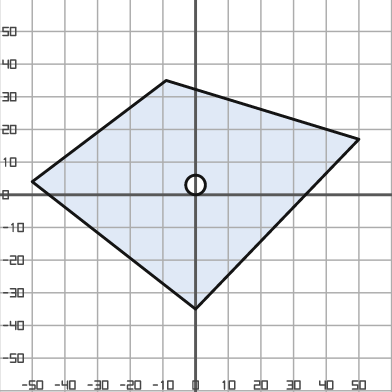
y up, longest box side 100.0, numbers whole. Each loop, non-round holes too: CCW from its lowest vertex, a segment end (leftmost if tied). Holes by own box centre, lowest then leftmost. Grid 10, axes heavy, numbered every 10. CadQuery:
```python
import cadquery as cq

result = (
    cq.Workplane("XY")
    .moveTo(0.0, -35.0)
    .lineTo(50.0, 17.0)
    .lineTo(-9.0, 35.0)
    .lineTo(-50.0, 4.0)
    .close()
    .moveTo(0.0, 3.0)
    .circle(3.0)
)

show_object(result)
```